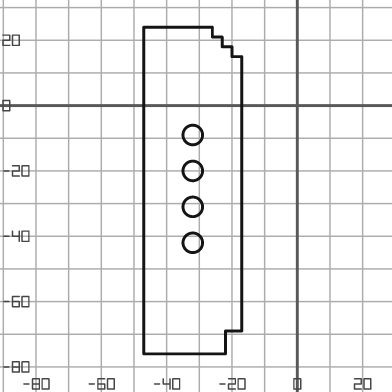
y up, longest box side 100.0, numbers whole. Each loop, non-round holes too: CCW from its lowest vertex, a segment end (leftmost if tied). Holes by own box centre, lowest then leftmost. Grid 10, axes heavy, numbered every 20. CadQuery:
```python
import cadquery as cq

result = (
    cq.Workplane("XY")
    .moveTo(-47.0, -76.0)
    .lineTo(-22.0, -76.0)
    .lineTo(-22.0, -69.0)
    .lineTo(-17.0, -69.0)
    .lineTo(-17.0, 15.0)
    .lineTo(-20.0, 15.0)
    .lineTo(-20.0, 18.0)
    .lineTo(-23.0, 18.0)
    .lineTo(-23.0, 21.0)
    .lineTo(-26.0, 21.0)
    .lineTo(-26.0, 24.0)
    .lineTo(-47.0, 24.0)
    .close()
    .moveTo(-32.0, -42.0)
    .circle(3.0)
    .moveTo(-32.0, -31.0)
    .circle(3.0)
    .moveTo(-32.0, -20.0)
    .circle(3.0)
    .moveTo(-32.0, -9.0)
    .circle(3.0)
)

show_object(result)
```